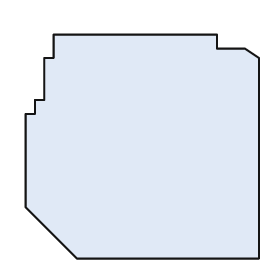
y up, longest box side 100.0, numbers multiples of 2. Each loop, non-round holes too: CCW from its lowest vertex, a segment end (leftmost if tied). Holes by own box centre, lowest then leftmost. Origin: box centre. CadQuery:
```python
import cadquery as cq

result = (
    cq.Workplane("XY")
    .moveTo(-28.0, -48.0)
    .lineTo(50.0, -48.0)
    .lineTo(50.0, 38.0)
    .lineTo(44.0, 42.0)
    .lineTo(32.0, 42.0)
    .lineTo(32.0, 48.0)
    .lineTo(-38.0, 48.0)
    .lineTo(-38.0, 38.0)
    .lineTo(-42.0, 38.0)
    .lineTo(-42.0, 20.0)
    .lineTo(-46.0, 20.0)
    .lineTo(-46.0, 14.0)
    .lineTo(-50.0, 14.0)
    .lineTo(-50.0, -26.0)
    .close()
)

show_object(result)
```